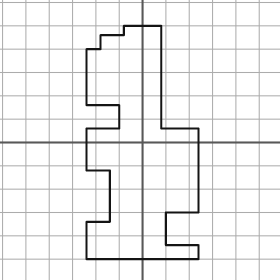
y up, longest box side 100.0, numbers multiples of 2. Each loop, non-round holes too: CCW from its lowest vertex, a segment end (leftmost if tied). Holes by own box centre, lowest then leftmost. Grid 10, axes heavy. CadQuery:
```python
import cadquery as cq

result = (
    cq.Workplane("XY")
    .moveTo(-24.0, -50.0)
    .lineTo(24.0, -50.0)
    .lineTo(24.0, -44.0)
    .lineTo(10.0, -44.0)
    .lineTo(10.0, -30.0)
    .lineTo(24.0, -30.0)
    .lineTo(24.0, 6.0)
    .lineTo(8.0, 6.0)
    .lineTo(8.0, 50.0)
    .lineTo(-8.0, 50.0)
    .lineTo(-8.0, 46.0)
    .lineTo(-18.0, 46.0)
    .lineTo(-18.0, 40.0)
    .lineTo(-24.0, 40.0)
    .lineTo(-24.0, 16.0)
    .lineTo(-10.0, 16.0)
    .lineTo(-10.0, 6.0)
    .lineTo(-24.0, 6.0)
    .lineTo(-24.0, -12.0)
    .lineTo(-14.0, -12.0)
    .lineTo(-14.0, -34.0)
    .lineTo(-24.0, -34.0)
    .close()
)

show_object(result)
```